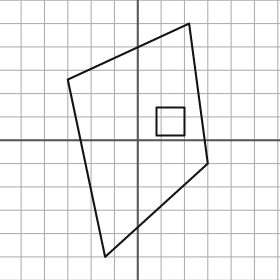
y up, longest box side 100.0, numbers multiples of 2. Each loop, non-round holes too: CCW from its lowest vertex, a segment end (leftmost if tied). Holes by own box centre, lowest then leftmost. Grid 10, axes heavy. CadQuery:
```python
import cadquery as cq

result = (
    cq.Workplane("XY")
    .moveTo(-14.0, -50.0)
    .lineTo(30.0, -10.0)
    .lineTo(22.0, 50.0)
    .lineTo(-30.0, 26.0)
    .close()
    .moveTo(8.0, 2.0)
    .lineTo(20.0, 2.0)
    .lineTo(20.0, 14.0)
    .lineTo(8.0, 14.0)
    .close()
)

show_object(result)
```